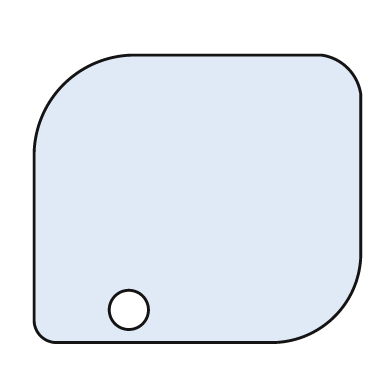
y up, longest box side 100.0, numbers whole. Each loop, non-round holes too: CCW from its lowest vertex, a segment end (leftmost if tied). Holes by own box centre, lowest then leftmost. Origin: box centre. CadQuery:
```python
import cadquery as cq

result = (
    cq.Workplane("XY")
    .moveTo(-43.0, -44.0)
    .lineTo(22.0, -44.0)
    .threePointArc((42.0, -36.0), (50.0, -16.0))
    .lineTo(50.0, 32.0)
    .threePointArc((46.0, 40.0), (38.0, 44.0))
    .lineTo(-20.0, 44.0)
    .threePointArc((-41.0, 35.0), (-50.0, 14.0))
    .lineTo(-50.0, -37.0)
    .threePointArc((-48.0, -42.0), (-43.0, -44.0))
    .close()
    .moveTo(-21.0, -34.0)
    .circle(6.0)
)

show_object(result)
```